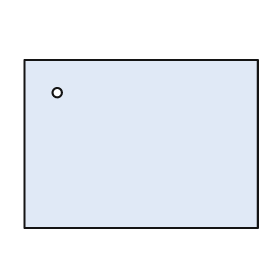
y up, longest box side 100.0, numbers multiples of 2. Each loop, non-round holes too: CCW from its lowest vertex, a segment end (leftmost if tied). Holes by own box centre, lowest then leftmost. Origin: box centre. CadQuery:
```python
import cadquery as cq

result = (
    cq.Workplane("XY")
    .moveTo(-50.0, -36.0)
    .lineTo(50.0, -36.0)
    .lineTo(50.0, 36.0)
    .lineTo(-50.0, 36.0)
    .close()
    .moveTo(-36.0, 22.0)
    .circle(2.0)
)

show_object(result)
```